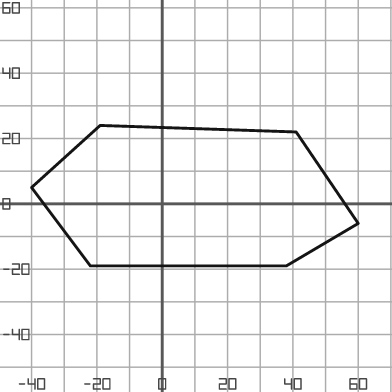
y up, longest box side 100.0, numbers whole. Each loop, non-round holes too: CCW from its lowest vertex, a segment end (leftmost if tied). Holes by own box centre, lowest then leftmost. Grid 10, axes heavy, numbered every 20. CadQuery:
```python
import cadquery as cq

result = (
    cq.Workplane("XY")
    .moveTo(-22.0, -19.0)
    .lineTo(38.0, -19.0)
    .lineTo(60.0, -6.0)
    .lineTo(41.0, 22.0)
    .lineTo(-19.0, 24.0)
    .lineTo(-40.0, 5.0)
    .close()
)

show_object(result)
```